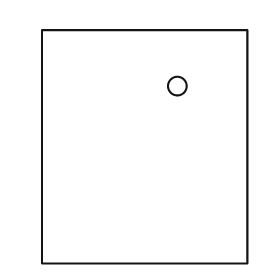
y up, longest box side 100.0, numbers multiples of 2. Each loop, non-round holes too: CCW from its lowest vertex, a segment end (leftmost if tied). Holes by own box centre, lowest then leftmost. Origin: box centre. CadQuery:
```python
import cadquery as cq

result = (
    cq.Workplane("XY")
    .moveTo(-44.0, -50.0)
    .lineTo(44.0, -50.0)
    .lineTo(44.0, 50.0)
    .lineTo(-44.0, 50.0)
    .close()
    .moveTo(14.0, 26.0)
    .circle(4.0)
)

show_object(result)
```